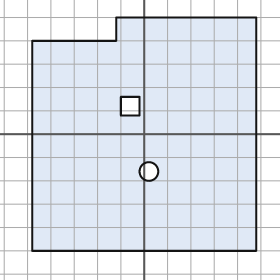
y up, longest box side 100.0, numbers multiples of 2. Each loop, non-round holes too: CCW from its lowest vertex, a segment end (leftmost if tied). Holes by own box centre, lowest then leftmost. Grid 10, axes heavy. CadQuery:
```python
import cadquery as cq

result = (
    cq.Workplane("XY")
    .moveTo(-48.0, -50.0)
    .lineTo(48.0, -50.0)
    .lineTo(48.0, 50.0)
    .lineTo(-12.0, 50.0)
    .lineTo(-12.0, 40.0)
    .lineTo(-48.0, 40.0)
    .close()
    .moveTo(2.0, -16.0)
    .circle(4.0)
    .moveTo(-10.0, 8.0)
    .lineTo(-2.0, 8.0)
    .lineTo(-2.0, 16.0)
    .lineTo(-10.0, 16.0)
    .close()
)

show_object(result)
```